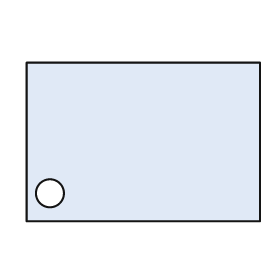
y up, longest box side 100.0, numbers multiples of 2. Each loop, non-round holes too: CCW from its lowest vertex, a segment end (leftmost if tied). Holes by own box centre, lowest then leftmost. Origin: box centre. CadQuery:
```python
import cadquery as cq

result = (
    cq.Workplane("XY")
    .moveTo(-50.0, -34.0)
    .lineTo(50.0, -34.0)
    .lineTo(50.0, 34.0)
    .lineTo(-50.0, 34.0)
    .close()
    .moveTo(-40.0, -22.0)
    .circle(6.0)
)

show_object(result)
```